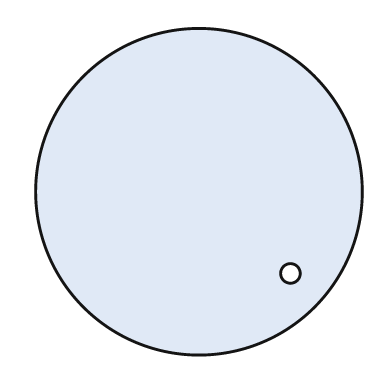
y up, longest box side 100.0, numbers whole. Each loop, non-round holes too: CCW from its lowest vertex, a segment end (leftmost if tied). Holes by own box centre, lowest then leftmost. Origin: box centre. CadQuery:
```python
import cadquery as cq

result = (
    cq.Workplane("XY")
    .moveTo(0.0, 0.0)
    .circle(50.0)
    .moveTo(28.0, -25.0)
    .circle(3.0)
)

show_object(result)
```